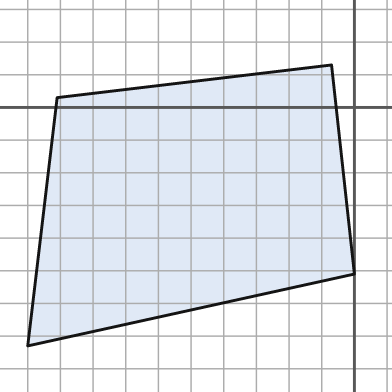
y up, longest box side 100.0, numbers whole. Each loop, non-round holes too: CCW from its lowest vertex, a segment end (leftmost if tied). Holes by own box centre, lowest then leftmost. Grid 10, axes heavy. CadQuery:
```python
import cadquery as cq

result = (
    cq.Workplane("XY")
    .moveTo(-100.0, -73.0)
    .lineTo(0.0, -51.0)
    .lineTo(-7.0, 13.0)
    .lineTo(-91.0, 3.0)
    .close()
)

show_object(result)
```